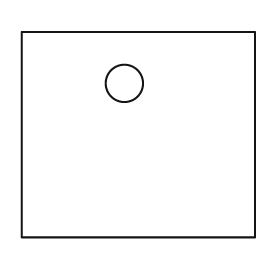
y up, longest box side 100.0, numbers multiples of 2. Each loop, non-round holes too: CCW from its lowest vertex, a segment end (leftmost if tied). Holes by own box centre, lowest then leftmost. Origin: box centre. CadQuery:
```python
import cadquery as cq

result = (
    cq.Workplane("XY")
    .moveTo(-50.0, -44.0)
    .lineTo(50.0, -44.0)
    .lineTo(50.0, 44.0)
    .lineTo(-50.0, 44.0)
    .close()
    .moveTo(-6.0, 22.0)
    .circle(8.0)
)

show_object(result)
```